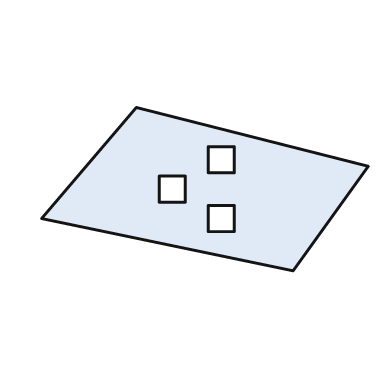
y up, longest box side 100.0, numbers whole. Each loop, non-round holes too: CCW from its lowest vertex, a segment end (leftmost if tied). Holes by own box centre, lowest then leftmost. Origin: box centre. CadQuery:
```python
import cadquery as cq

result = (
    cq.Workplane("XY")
    .moveTo(27.0, -25.0)
    .lineTo(50.0, 7.0)
    .lineTo(-21.0, 25.0)
    .lineTo(-50.0, -9.0)
    .close()
    .moveTo(1.0, -13.0)
    .lineTo(9.0, -13.0)
    .lineTo(9.0, -5.0)
    .lineTo(1.0, -5.0)
    .close()
    .moveTo(-14.0, -4.0)
    .lineTo(-6.0, -4.0)
    .lineTo(-6.0, 4.0)
    .lineTo(-14.0, 4.0)
    .close()
    .moveTo(1.0, 5.0)
    .lineTo(9.0, 5.0)
    .lineTo(9.0, 13.0)
    .lineTo(1.0, 13.0)
    .close()
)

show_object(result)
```